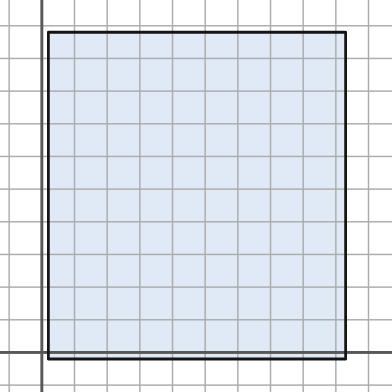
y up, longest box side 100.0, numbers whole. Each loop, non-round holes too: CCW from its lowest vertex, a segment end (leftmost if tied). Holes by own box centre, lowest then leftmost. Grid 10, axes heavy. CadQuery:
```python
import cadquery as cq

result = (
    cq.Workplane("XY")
    .moveTo(2.0, -2.0)
    .lineTo(93.0, -2.0)
    .lineTo(93.0, 98.0)
    .lineTo(2.0, 98.0)
    .close()
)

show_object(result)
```